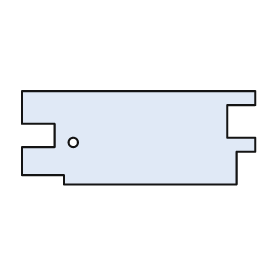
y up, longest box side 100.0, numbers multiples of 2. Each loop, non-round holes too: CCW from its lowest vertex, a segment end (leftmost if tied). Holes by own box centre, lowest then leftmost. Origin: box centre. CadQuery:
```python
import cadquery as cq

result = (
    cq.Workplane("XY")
    .moveTo(-32.0, -20.0)
    .lineTo(42.0, -20.0)
    .lineTo(42.0, -6.0)
    .lineTo(50.0, -6.0)
    .lineTo(50.0, 0.0)
    .lineTo(38.0, 0.0)
    .lineTo(38.0, 14.0)
    .lineTo(50.0, 14.0)
    .lineTo(50.0, 20.0)
    .lineTo(-50.0, 20.0)
    .lineTo(-50.0, 6.0)
    .lineTo(-36.0, 6.0)
    .lineTo(-36.0, -4.0)
    .lineTo(-50.0, -4.0)
    .lineTo(-50.0, -16.0)
    .lineTo(-32.0, -16.0)
    .close()
    .moveTo(-28.0, -2.0)
    .circle(2.0)
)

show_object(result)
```